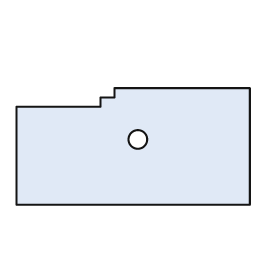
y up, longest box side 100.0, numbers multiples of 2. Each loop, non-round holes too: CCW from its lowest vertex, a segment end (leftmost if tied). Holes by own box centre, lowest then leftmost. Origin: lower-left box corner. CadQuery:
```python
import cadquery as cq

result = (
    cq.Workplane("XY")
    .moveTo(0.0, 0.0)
    .lineTo(100.0, 0.0)
    .lineTo(100.0, 50.0)
    .lineTo(42.0, 50.0)
    .lineTo(42.0, 46.0)
    .lineTo(36.0, 46.0)
    .lineTo(36.0, 42.0)
    .lineTo(0.0, 42.0)
    .close()
    .moveTo(52.0, 28.0)
    .circle(4.0)
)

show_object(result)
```